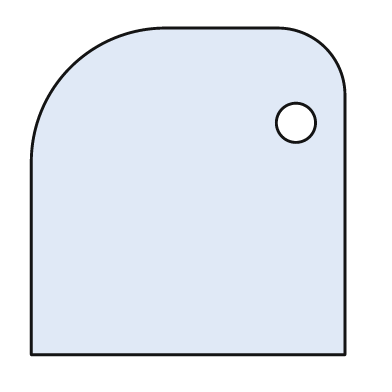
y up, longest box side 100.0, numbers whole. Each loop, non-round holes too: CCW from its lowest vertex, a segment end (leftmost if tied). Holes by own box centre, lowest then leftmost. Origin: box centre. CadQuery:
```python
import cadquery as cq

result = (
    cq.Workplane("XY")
    .moveTo(-48.0, -50.0)
    .lineTo(48.0, -50.0)
    .lineTo(48.0, 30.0)
    .threePointArc((42.0, 44.0), (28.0, 50.0))
    .lineTo(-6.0, 50.0)
    .threePointArc((-36.0, 38.0), (-48.0, 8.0))
    .close()
    .moveTo(33.0, 21.0)
    .circle(6.0)
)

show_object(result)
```